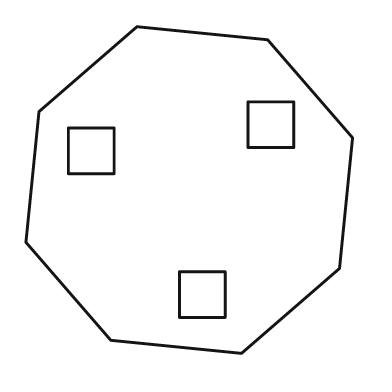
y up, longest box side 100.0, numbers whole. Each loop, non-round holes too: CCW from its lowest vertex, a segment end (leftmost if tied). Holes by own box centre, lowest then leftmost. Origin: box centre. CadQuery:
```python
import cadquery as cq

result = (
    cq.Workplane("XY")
    .moveTo(16.0, -50.0)
    .lineTo(46.0, -24.0)
    .lineTo(50.0, 16.0)
    .lineTo(24.0, 46.0)
    .lineTo(-16.0, 50.0)
    .lineTo(-46.0, 24.0)
    .lineTo(-50.0, -16.0)
    .lineTo(-24.0, -46.0)
    .close()
    .moveTo(-3.0, -39.0)
    .lineTo(11.0, -39.0)
    .lineTo(11.0, -25.0)
    .lineTo(-3.0, -25.0)
    .close()
    .moveTo(-37.0, 5.0)
    .lineTo(-23.0, 5.0)
    .lineTo(-23.0, 19.0)
    .lineTo(-37.0, 19.0)
    .close()
    .moveTo(18.0, 13.0)
    .lineTo(32.0, 13.0)
    .lineTo(32.0, 27.0)
    .lineTo(18.0, 27.0)
    .close()
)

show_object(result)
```